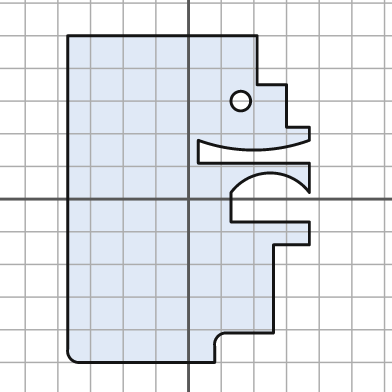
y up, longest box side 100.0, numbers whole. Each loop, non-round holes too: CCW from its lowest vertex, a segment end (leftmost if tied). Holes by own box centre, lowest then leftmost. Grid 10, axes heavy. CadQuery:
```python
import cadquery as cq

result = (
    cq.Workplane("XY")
    .moveTo(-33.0, -50.0)
    .lineTo(8.0, -50.0)
    .lineTo(8.0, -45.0)
    .threePointArc((9.0, -42.0), (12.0, -41.0))
    .lineTo(26.0, -41.0)
    .lineTo(26.0, -14.0)
    .lineTo(37.0, -14.0)
    .lineTo(37.0, -7.0)
    .lineTo(13.0, -7.0)
    .lineTo(13.0, 2.0)
    .threePointArc((25.0, 8.0), (37.0, 2.0))
    .lineTo(37.0, 11.0)
    .lineTo(3.0, 11.0)
    .lineTo(3.0, 18.0)
    .threePointArc((20.0, 15.0), (37.0, 18.0))
    .lineTo(37.0, 22.0)
    .lineTo(30.0, 22.0)
    .lineTo(30.0, 35.0)
    .lineTo(21.0, 35.0)
    .lineTo(21.0, 50.0)
    .lineTo(-37.0, 50.0)
    .lineTo(-37.0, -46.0)
    .threePointArc((-36.0, -49.0), (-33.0, -50.0))
    .close()
    .moveTo(16.0, 30.0)
    .circle(3.0)
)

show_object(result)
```